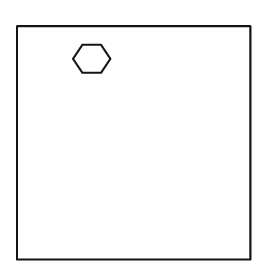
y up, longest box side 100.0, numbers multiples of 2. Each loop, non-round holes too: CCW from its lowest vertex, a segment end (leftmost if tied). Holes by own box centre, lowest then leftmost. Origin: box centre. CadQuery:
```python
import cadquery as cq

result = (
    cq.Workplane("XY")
    .moveTo(-50.0, -50.0)
    .lineTo(50.0, -50.0)
    .lineTo(50.0, 50.0)
    .lineTo(-50.0, 50.0)
    .close()
    .moveTo(-22.0, 30.0)
    .lineTo(-14.0, 30.0)
    .lineTo(-10.0, 36.0)
    .lineTo(-14.0, 42.0)
    .lineTo(-22.0, 42.0)
    .lineTo(-26.0, 36.0)
    .close()
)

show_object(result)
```